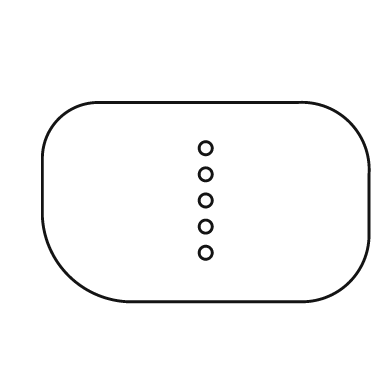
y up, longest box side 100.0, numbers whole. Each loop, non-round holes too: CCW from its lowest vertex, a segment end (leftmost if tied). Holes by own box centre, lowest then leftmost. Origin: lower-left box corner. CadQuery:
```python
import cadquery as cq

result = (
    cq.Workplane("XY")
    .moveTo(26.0, 0.0)
    .lineTo(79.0, 0.0)
    .threePointArc((94.0, 6.0), (100.0, 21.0))
    .lineTo(100.0, 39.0)
    .threePointArc((94.0, 55.0), (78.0, 61.0))
    .lineTo(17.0, 61.0)
    .threePointArc((5.0, 56.0), (0.0, 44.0))
    .lineTo(0.0, 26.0)
    .threePointArc((8.0, 8.0), (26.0, 0.0))
    .close()
    .moveTo(50.0, 15.0)
    .circle(2.0)
    .moveTo(50.0, 23.0)
    .circle(2.0)
    .moveTo(50.0, 31.0)
    .circle(2.0)
    .moveTo(50.0, 39.0)
    .circle(2.0)
    .moveTo(50.0, 47.0)
    .circle(2.0)
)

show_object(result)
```